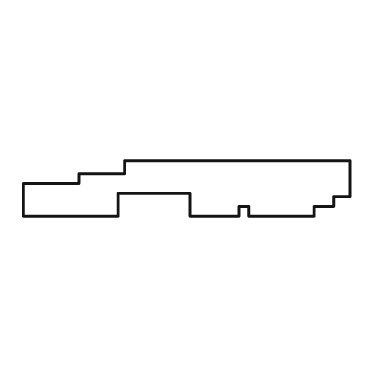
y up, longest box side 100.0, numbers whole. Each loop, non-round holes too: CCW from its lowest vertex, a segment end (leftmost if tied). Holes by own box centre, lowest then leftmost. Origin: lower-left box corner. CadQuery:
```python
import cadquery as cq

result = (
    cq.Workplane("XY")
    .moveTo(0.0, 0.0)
    .lineTo(29.0, 0.0)
    .lineTo(29.0, 7.0)
    .lineTo(51.0, 7.0)
    .lineTo(51.0, 0.0)
    .lineTo(66.0, 0.0)
    .lineTo(66.0, 3.0)
    .lineTo(69.0, 3.0)
    .lineTo(69.0, 0.0)
    .lineTo(89.0, 0.0)
    .lineTo(89.0, 3.0)
    .lineTo(95.0, 3.0)
    .lineTo(95.0, 6.0)
    .lineTo(100.0, 6.0)
    .lineTo(100.0, 17.0)
    .lineTo(31.0, 17.0)
    .lineTo(31.0, 13.0)
    .lineTo(17.0, 13.0)
    .lineTo(17.0, 10.0)
    .lineTo(0.0, 10.0)
    .close()
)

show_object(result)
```